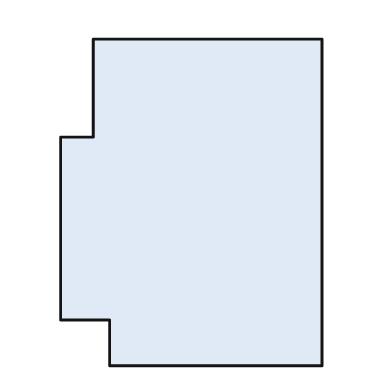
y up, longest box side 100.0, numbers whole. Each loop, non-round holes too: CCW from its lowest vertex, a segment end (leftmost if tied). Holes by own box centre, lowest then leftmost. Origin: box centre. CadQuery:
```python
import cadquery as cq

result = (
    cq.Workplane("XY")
    .moveTo(-25.0, -50.0)
    .lineTo(40.0, -50.0)
    .lineTo(40.0, 50.0)
    .lineTo(-30.0, 50.0)
    .lineTo(-30.0, 20.0)
    .lineTo(-40.0, 20.0)
    .lineTo(-40.0, -36.0)
    .lineTo(-25.0, -36.0)
    .close()
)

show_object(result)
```